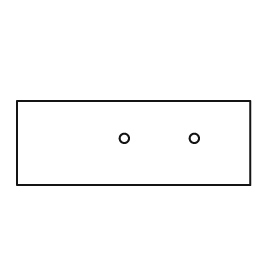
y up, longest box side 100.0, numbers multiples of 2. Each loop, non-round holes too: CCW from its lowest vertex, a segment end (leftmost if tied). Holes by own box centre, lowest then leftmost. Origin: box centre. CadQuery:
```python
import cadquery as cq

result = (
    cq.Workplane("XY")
    .moveTo(-50.0, -18.0)
    .lineTo(50.0, -18.0)
    .lineTo(50.0, 18.0)
    .lineTo(-50.0, 18.0)
    .close()
    .moveTo(-4.0, 2.0)
    .circle(2.0)
    .moveTo(26.0, 2.0)
    .circle(2.0)
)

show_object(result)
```